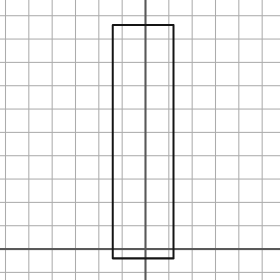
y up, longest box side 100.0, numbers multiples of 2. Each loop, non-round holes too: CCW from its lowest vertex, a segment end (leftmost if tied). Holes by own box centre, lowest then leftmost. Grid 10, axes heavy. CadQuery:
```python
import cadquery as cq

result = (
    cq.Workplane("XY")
    .moveTo(-14.0, -4.0)
    .lineTo(12.0, -4.0)
    .lineTo(12.0, 96.0)
    .lineTo(-14.0, 96.0)
    .close()
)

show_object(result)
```